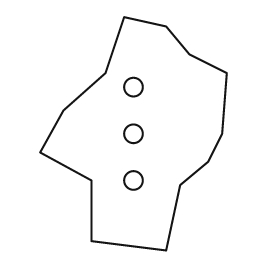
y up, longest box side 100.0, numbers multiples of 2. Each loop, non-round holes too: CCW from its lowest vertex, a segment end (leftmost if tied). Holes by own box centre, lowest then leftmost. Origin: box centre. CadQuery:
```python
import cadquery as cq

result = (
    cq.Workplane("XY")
    .moveTo(14.0, -50.0)
    .lineTo(20.0, -22.0)
    .lineTo(32.0, -12.0)
    .lineTo(38.0, 0.0)
    .lineTo(40.0, 26.0)
    .lineTo(24.0, 34.0)
    .lineTo(14.0, 46.0)
    .lineTo(-4.0, 50.0)
    .lineTo(-12.0, 26.0)
    .lineTo(-30.0, 10.0)
    .lineTo(-40.0, -8.0)
    .lineTo(-18.0, -20.0)
    .lineTo(-18.0, -46.0)
    .close()
    .moveTo(0.0, -20.0)
    .circle(4.0)
    .moveTo(0.0, 0.0)
    .circle(4.0)
    .moveTo(0.0, 20.0)
    .circle(4.0)
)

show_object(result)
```